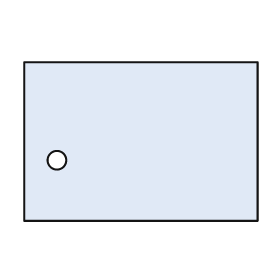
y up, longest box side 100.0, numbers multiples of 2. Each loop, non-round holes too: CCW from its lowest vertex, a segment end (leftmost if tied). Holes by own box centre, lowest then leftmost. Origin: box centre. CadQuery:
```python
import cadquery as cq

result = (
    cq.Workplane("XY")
    .moveTo(-50.0, -34.0)
    .lineTo(50.0, -34.0)
    .lineTo(50.0, 34.0)
    .lineTo(-50.0, 34.0)
    .close()
    .moveTo(-36.0, -8.0)
    .circle(4.0)
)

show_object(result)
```